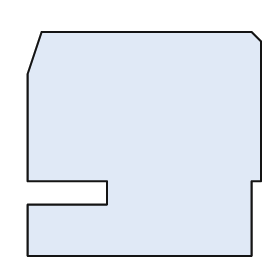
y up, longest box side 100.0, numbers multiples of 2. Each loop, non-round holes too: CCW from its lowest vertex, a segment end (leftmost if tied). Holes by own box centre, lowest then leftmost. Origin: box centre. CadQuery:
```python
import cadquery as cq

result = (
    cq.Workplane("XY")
    .moveTo(-50.0, -48.0)
    .lineTo(46.0, -48.0)
    .lineTo(46.0, -16.0)
    .lineTo(50.0, -16.0)
    .lineTo(50.0, 44.0)
    .lineTo(46.0, 48.0)
    .lineTo(-44.0, 48.0)
    .lineTo(-50.0, 30.0)
    .lineTo(-50.0, -16.0)
    .lineTo(-16.0, -16.0)
    .lineTo(-16.0, -26.0)
    .lineTo(-50.0, -26.0)
    .close()
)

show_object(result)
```